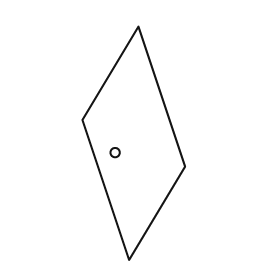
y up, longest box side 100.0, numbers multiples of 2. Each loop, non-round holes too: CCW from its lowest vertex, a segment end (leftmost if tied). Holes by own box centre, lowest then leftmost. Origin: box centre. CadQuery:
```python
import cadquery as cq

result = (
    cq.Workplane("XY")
    .moveTo(-2.0, -50.0)
    .lineTo(22.0, -10.0)
    .lineTo(2.0, 50.0)
    .lineTo(-22.0, 10.0)
    .close()
    .moveTo(-8.0, -4.0)
    .circle(2.0)
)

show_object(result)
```